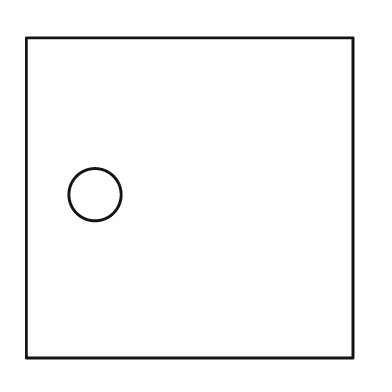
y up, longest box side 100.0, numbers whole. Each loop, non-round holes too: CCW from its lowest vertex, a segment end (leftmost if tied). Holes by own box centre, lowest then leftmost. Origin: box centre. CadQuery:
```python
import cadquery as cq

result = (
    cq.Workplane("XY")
    .moveTo(-50.0, -49.0)
    .lineTo(50.0, -49.0)
    .lineTo(50.0, 49.0)
    .lineTo(-50.0, 49.0)
    .close()
    .moveTo(-29.0, 1.0)
    .circle(8.0)
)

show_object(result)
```